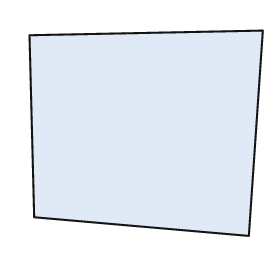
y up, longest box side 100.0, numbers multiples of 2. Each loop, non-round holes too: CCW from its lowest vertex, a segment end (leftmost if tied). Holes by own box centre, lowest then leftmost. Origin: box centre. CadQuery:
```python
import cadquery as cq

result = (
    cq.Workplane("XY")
    .moveTo(44.0, -44.0)
    .lineTo(50.0, 44.0)
    .lineTo(-50.0, 42.0)
    .lineTo(-48.0, -36.0)
    .close()
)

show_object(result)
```